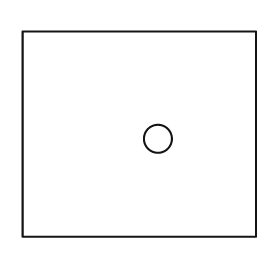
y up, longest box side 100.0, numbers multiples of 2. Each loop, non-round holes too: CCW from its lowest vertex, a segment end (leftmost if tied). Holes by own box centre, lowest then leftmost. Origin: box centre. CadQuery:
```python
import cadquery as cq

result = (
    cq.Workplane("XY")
    .moveTo(-50.0, -44.0)
    .lineTo(50.0, -44.0)
    .lineTo(50.0, 44.0)
    .lineTo(-50.0, 44.0)
    .close()
    .moveTo(8.0, -2.0)
    .circle(6.0)
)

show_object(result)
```